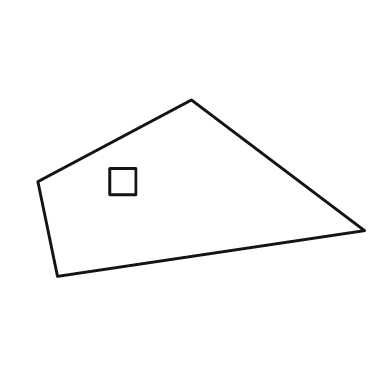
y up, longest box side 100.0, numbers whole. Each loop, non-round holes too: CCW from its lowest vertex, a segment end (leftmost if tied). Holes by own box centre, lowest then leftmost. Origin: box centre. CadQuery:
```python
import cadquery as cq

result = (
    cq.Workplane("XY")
    .moveTo(-44.0, -27.0)
    .lineTo(50.0, -13.0)
    .lineTo(-3.0, 27.0)
    .lineTo(-50.0, 2.0)
    .close()
    .moveTo(-28.0, -2.0)
    .lineTo(-20.0, -2.0)
    .lineTo(-20.0, 6.0)
    .lineTo(-28.0, 6.0)
    .close()
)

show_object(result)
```